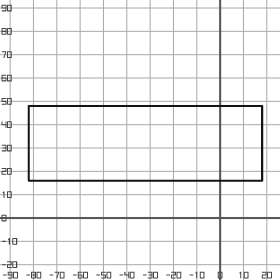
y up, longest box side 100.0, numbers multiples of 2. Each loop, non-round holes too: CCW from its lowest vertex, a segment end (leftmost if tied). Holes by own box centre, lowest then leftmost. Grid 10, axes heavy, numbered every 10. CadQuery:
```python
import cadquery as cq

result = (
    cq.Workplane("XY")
    .moveTo(-82.0, 16.0)
    .lineTo(18.0, 16.0)
    .lineTo(18.0, 48.0)
    .lineTo(-82.0, 48.0)
    .close()
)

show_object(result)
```